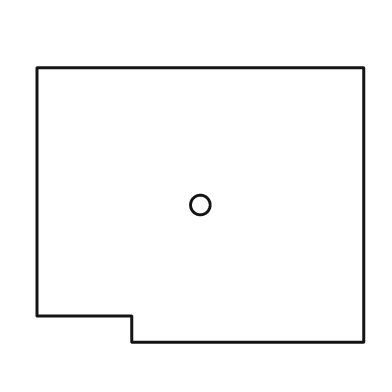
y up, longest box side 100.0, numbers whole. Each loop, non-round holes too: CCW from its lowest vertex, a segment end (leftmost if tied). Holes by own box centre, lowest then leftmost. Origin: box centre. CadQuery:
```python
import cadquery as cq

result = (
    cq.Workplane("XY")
    .moveTo(-21.0, -42.0)
    .lineTo(50.0, -42.0)
    .lineTo(50.0, 42.0)
    .lineTo(-50.0, 42.0)
    .lineTo(-50.0, -34.0)
    .lineTo(-21.0, -34.0)
    .close()
    .moveTo(0.0, 0.0)
    .circle(3.0)
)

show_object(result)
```